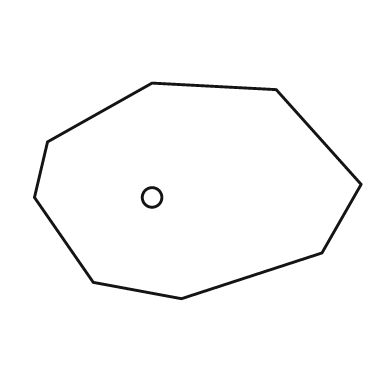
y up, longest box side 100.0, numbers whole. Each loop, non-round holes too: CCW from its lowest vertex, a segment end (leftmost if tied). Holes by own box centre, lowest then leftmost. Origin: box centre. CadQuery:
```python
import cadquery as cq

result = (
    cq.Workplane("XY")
    .moveTo(-5.0, -33.0)
    .lineTo(38.0, -19.0)
    .lineTo(50.0, 2.0)
    .lineTo(24.0, 31.0)
    .lineTo(-14.0, 33.0)
    .lineTo(-46.0, 15.0)
    .lineTo(-50.0, -2.0)
    .lineTo(-32.0, -28.0)
    .close()
    .moveTo(-14.0, -2.0)
    .circle(3.0)
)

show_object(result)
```